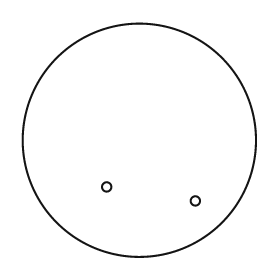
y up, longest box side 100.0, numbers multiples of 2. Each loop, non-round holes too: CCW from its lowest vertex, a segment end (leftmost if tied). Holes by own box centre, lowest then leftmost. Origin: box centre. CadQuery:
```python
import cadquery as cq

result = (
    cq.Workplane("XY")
    .moveTo(0.0, 0.0)
    .circle(50.0)
    .moveTo(24.0, -26.0)
    .circle(2.0)
    .moveTo(-14.0, -20.0)
    .circle(2.0)
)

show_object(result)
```